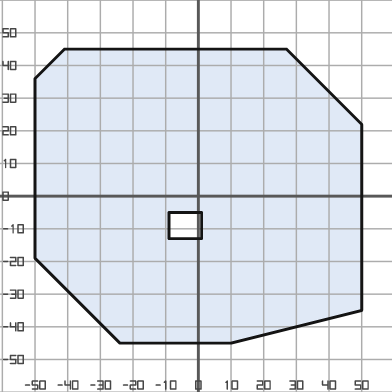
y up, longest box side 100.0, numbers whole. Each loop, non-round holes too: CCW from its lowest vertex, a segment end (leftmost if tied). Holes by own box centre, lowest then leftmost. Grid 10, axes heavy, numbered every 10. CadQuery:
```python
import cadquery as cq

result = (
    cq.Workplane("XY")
    .moveTo(-24.0, -45.0)
    .lineTo(10.0, -45.0)
    .lineTo(50.0, -35.0)
    .lineTo(50.0, 22.0)
    .lineTo(27.0, 45.0)
    .lineTo(-41.0, 45.0)
    .lineTo(-50.0, 36.0)
    .lineTo(-50.0, -19.0)
    .close()
    .moveTo(-9.0, -13.0)
    .lineTo(1.0, -13.0)
    .lineTo(1.0, -5.0)
    .lineTo(-9.0, -5.0)
    .close()
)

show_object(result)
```